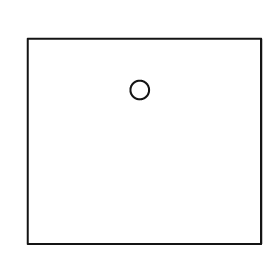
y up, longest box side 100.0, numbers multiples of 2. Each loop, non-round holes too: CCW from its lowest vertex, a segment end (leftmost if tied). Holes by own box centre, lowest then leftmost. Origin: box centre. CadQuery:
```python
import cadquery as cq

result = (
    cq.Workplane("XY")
    .moveTo(-50.0, -44.0)
    .lineTo(50.0, -44.0)
    .lineTo(50.0, 44.0)
    .lineTo(-50.0, 44.0)
    .close()
    .moveTo(-2.0, 22.0)
    .circle(4.0)
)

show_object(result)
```